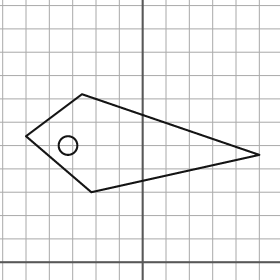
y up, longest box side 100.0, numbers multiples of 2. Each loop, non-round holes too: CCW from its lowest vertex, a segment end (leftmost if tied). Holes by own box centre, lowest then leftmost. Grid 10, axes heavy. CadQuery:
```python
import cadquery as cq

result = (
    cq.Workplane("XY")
    .moveTo(-22.0, 30.0)
    .lineTo(50.0, 46.0)
    .lineTo(-26.0, 72.0)
    .lineTo(-50.0, 54.0)
    .close()
    .moveTo(-32.0, 50.0)
    .circle(4.0)
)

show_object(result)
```